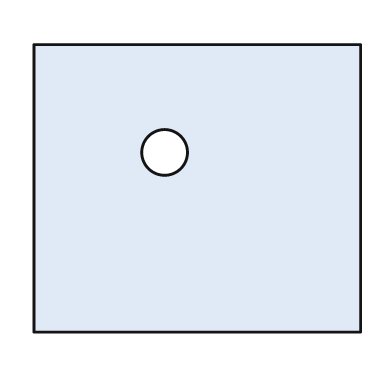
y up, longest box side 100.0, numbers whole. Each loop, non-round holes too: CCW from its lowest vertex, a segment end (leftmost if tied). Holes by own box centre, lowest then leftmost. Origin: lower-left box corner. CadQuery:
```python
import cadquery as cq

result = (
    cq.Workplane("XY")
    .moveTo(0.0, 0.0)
    .lineTo(100.0, 0.0)
    .lineTo(100.0, 88.0)
    .lineTo(0.0, 88.0)
    .close()
    .moveTo(40.0, 55.0)
    .circle(7.0)
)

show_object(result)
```